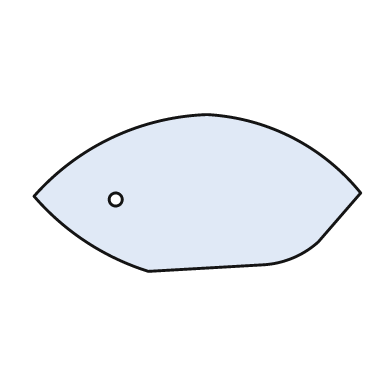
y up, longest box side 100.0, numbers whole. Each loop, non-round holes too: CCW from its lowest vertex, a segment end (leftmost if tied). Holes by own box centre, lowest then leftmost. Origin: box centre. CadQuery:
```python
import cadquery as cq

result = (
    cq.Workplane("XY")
    .moveTo(-15.0, -24.0)
    .lineTo(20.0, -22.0)
    .threePointArc((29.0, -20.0), (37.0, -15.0))
    .lineTo(50.0, 0.0)
    .threePointArc((29.0, 17.0), (3.0, 24.0))
    .threePointArc((-26.0, 17.0), (-50.0, -1.0))
    .threePointArc((-34.0, -15.0), (-15.0, -24.0))
    .close()
    .moveTo(-25.0, -2.0)
    .circle(2.0)
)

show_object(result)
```